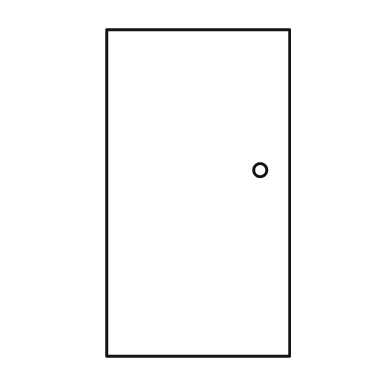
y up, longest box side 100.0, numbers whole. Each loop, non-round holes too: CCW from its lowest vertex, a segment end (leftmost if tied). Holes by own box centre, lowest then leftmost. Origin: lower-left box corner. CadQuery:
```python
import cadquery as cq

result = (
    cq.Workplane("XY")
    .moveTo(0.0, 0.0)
    .lineTo(56.0, 0.0)
    .lineTo(56.0, 100.0)
    .lineTo(0.0, 100.0)
    .close()
    .moveTo(47.0, 57.0)
    .circle(2.0)
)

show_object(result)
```